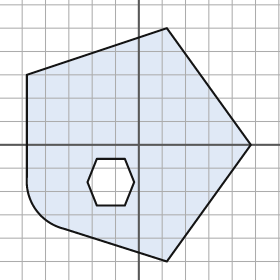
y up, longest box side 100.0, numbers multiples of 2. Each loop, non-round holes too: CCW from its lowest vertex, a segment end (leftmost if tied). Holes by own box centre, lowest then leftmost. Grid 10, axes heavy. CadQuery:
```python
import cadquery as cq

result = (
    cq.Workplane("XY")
    .moveTo(12.0, -50.0)
    .lineTo(48.0, 0.0)
    .lineTo(12.0, 50.0)
    .lineTo(-48.0, 30.0)
    .lineTo(-48.0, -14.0)
    .threePointArc((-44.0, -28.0), (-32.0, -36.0))
    .close()
    .moveTo(-18.0, -26.0)
    .lineTo(-6.0, -26.0)
    .lineTo(-2.0, -16.0)
    .lineTo(-6.0, -6.0)
    .lineTo(-18.0, -6.0)
    .lineTo(-22.0, -16.0)
    .close()
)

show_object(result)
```